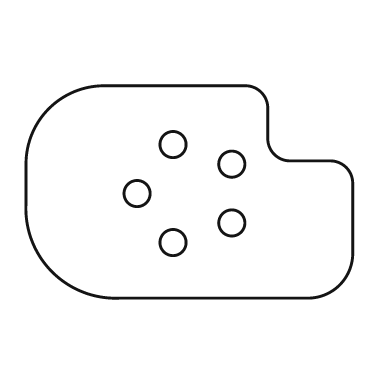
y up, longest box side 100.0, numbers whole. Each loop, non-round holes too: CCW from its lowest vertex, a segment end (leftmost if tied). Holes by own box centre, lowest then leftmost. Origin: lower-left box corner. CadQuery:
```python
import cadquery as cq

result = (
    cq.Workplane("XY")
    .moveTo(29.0, 0.0)
    .lineTo(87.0, 0.0)
    .threePointArc((96.0, 4.0), (100.0, 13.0))
    .lineTo(100.0, 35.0)
    .threePointArc((98.0, 40.0), (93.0, 42.0))
    .lineTo(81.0, 42.0)
    .threePointArc((76.0, 44.0), (74.0, 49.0))
    .lineTo(74.0, 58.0)
    .threePointArc((72.0, 63.0), (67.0, 65.0))
    .lineTo(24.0, 65.0)
    .threePointArc((7.0, 58.0), (0.0, 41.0))
    .lineTo(0.0, 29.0)
    .threePointArc((8.0, 8.0), (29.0, 0.0))
    .close()
    .moveTo(45.0, 17.0)
    .circle(4.0)
    .moveTo(63.0, 23.0)
    .circle(4.0)
    .moveTo(34.0, 32.0)
    .circle(4.0)
    .moveTo(63.0, 41.0)
    .circle(4.0)
    .moveTo(45.0, 47.0)
    .circle(4.0)
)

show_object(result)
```